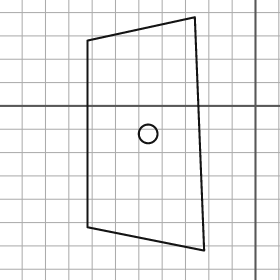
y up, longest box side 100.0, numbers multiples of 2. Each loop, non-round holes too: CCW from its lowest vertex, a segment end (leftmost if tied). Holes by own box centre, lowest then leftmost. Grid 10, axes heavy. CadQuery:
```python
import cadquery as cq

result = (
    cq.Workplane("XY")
    .moveTo(-22.0, -62.0)
    .lineTo(-26.0, 38.0)
    .lineTo(-72.0, 28.0)
    .lineTo(-72.0, -52.0)
    .close()
    .moveTo(-46.0, -12.0)
    .circle(4.0)
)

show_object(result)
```